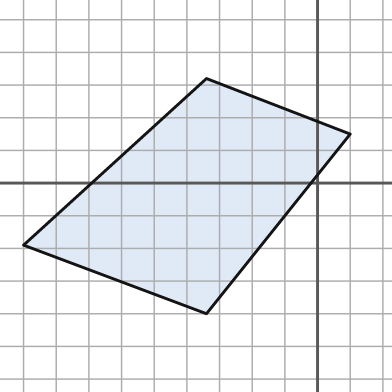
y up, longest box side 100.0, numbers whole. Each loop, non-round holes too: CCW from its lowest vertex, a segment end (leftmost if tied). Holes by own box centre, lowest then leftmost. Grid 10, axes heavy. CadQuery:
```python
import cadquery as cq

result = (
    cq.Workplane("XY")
    .moveTo(-34.0, -40.0)
    .lineTo(10.0, 15.0)
    .lineTo(-34.0, 32.0)
    .lineTo(-90.0, -19.0)
    .close()
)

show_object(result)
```